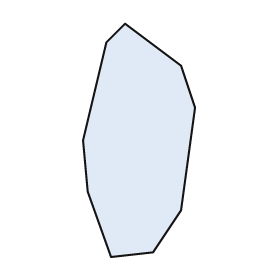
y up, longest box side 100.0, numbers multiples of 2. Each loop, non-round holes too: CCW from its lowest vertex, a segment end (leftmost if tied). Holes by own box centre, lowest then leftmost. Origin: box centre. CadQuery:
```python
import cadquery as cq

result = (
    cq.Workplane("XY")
    .moveTo(-12.0, -50.0)
    .lineTo(6.0, -48.0)
    .lineTo(18.0, -30.0)
    .lineTo(24.0, 14.0)
    .lineTo(18.0, 32.0)
    .lineTo(-6.0, 50.0)
    .lineTo(-14.0, 42.0)
    .lineTo(-24.0, 0.0)
    .lineTo(-22.0, -22.0)
    .close()
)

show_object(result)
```